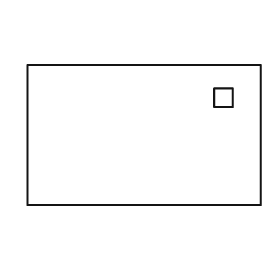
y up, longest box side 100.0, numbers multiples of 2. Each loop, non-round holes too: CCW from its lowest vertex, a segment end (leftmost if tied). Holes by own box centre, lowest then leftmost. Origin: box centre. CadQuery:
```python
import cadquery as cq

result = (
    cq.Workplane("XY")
    .moveTo(-50.0, -30.0)
    .lineTo(50.0, -30.0)
    .lineTo(50.0, 30.0)
    .lineTo(-50.0, 30.0)
    .close()
    .moveTo(30.0, 12.0)
    .lineTo(38.0, 12.0)
    .lineTo(38.0, 20.0)
    .lineTo(30.0, 20.0)
    .close()
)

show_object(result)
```